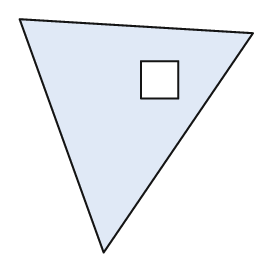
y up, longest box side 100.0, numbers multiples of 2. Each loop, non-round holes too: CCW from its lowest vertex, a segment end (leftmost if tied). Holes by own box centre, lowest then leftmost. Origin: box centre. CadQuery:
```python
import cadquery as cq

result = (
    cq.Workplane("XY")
    .moveTo(-14.0, -50.0)
    .lineTo(50.0, 44.0)
    .lineTo(-50.0, 50.0)
    .close()
    .moveTo(2.0, 16.0)
    .lineTo(18.0, 16.0)
    .lineTo(18.0, 32.0)
    .lineTo(2.0, 32.0)
    .close()
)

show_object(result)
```